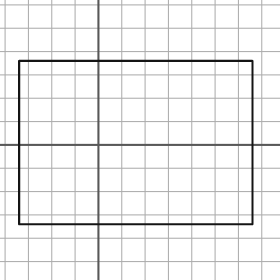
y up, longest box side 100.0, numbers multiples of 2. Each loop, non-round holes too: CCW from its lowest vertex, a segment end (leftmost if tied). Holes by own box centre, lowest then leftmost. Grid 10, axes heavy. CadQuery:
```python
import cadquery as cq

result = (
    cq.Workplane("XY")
    .moveTo(-34.0, -34.0)
    .lineTo(66.0, -34.0)
    .lineTo(66.0, 36.0)
    .lineTo(-34.0, 36.0)
    .close()
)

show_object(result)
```